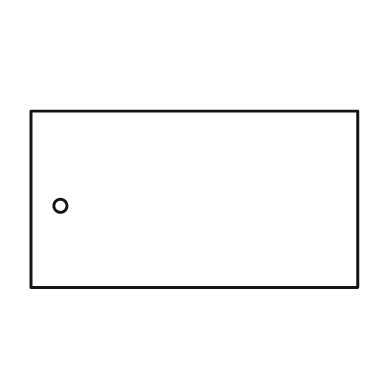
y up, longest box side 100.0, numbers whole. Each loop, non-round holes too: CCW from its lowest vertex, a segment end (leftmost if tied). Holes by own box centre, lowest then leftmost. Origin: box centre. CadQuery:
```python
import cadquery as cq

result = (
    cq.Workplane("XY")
    .moveTo(-50.0, -27.0)
    .lineTo(50.0, -27.0)
    .lineTo(50.0, 27.0)
    .lineTo(-50.0, 27.0)
    .close()
    .moveTo(-41.0, -2.0)
    .circle(2.0)
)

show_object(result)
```